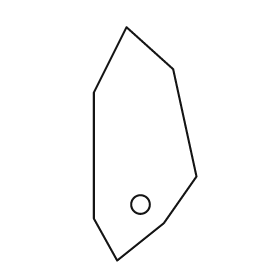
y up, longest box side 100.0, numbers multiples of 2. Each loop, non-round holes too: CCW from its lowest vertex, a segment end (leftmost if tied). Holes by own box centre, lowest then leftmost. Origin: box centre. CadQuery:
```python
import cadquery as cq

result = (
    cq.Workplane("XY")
    .moveTo(-12.0, -50.0)
    .lineTo(8.0, -34.0)
    .lineTo(22.0, -14.0)
    .lineTo(12.0, 32.0)
    .lineTo(-8.0, 50.0)
    .lineTo(-22.0, 22.0)
    .lineTo(-22.0, -32.0)
    .close()
    .moveTo(-2.0, -26.0)
    .circle(4.0)
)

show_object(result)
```